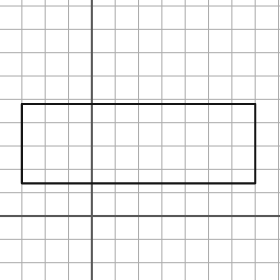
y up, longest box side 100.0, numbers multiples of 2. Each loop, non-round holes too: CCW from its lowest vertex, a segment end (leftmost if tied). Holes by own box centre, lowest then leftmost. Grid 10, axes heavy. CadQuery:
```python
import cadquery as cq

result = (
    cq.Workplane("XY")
    .moveTo(-30.0, 14.0)
    .lineTo(70.0, 14.0)
    .lineTo(70.0, 48.0)
    .lineTo(-30.0, 48.0)
    .close()
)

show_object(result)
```